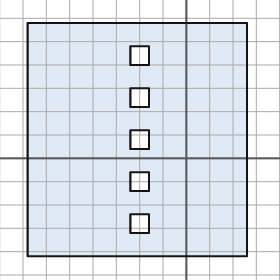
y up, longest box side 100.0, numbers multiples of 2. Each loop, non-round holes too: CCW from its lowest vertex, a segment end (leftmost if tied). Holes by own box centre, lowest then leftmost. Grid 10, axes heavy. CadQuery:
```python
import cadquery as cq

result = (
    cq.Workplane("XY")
    .moveTo(-68.0, -42.0)
    .lineTo(26.0, -42.0)
    .lineTo(26.0, 58.0)
    .lineTo(-68.0, 58.0)
    .close()
    .moveTo(-24.0, -32.0)
    .lineTo(-16.0, -32.0)
    .lineTo(-16.0, -24.0)
    .lineTo(-24.0, -24.0)
    .close()
    .moveTo(-24.0, -14.0)
    .lineTo(-16.0, -14.0)
    .lineTo(-16.0, -6.0)
    .lineTo(-24.0, -6.0)
    .close()
    .moveTo(-24.0, 4.0)
    .lineTo(-16.0, 4.0)
    .lineTo(-16.0, 12.0)
    .lineTo(-24.0, 12.0)
    .close()
    .moveTo(-24.0, 22.0)
    .lineTo(-16.0, 22.0)
    .lineTo(-16.0, 30.0)
    .lineTo(-24.0, 30.0)
    .close()
    .moveTo(-24.0, 40.0)
    .lineTo(-16.0, 40.0)
    .lineTo(-16.0, 48.0)
    .lineTo(-24.0, 48.0)
    .close()
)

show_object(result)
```